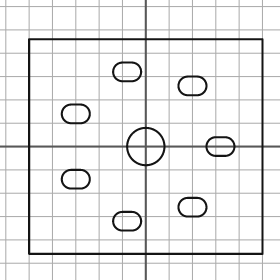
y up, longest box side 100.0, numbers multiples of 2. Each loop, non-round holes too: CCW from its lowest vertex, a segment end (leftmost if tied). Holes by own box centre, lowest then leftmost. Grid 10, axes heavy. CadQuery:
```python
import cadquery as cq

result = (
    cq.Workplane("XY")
    .moveTo(-50.0, -46.0)
    .lineTo(50.0, -46.0)
    .lineTo(50.0, 46.0)
    .lineTo(-50.0, 46.0)
    .close()
    .moveTo(-10.0, -36.0)
    .lineTo(-6.0, -36.0)
    .threePointArc((-2.0, -32.0), (-6.0, -28.0))
    .lineTo(-10.0, -28.0)
    .threePointArc((-14.0, -32.0), (-10.0, -36.0))
    .close()
    .moveTo(18.0, -30.0)
    .lineTo(22.0, -30.0)
    .threePointArc((26.0, -26.0), (22.0, -22.0))
    .lineTo(18.0, -22.0)
    .threePointArc((14.0, -26.0), (18.0, -30.0))
    .close()
    .moveTo(-32.0, -18.0)
    .lineTo(-28.0, -18.0)
    .threePointArc((-24.0, -14.0), (-28.0, -10.0))
    .lineTo(-32.0, -10.0)
    .threePointArc((-36.0, -14.0), (-32.0, -18.0))
    .close()
    .moveTo(0.0, 0.0)
    .circle(8.0)
    .moveTo(30.0, -4.0)
    .lineTo(34.0, -4.0)
    .threePointArc((38.0, 0.0), (34.0, 4.0))
    .lineTo(30.0, 4.0)
    .threePointArc((26.0, 0.0), (30.0, -4.0))
    .close()
    .moveTo(-32.0, 10.0)
    .lineTo(-28.0, 10.0)
    .threePointArc((-24.0, 14.0), (-28.0, 18.0))
    .lineTo(-32.0, 18.0)
    .threePointArc((-36.0, 14.0), (-32.0, 10.0))
    .close()
    .moveTo(18.0, 22.0)
    .lineTo(22.0, 22.0)
    .threePointArc((26.0, 26.0), (22.0, 30.0))
    .lineTo(18.0, 30.0)
    .threePointArc((14.0, 26.0), (18.0, 22.0))
    .close()
    .moveTo(-10.0, 28.0)
    .lineTo(-6.0, 28.0)
    .threePointArc((-2.0, 32.0), (-6.0, 36.0))
    .lineTo(-10.0, 36.0)
    .threePointArc((-14.0, 32.0), (-10.0, 28.0))
    .close()
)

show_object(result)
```